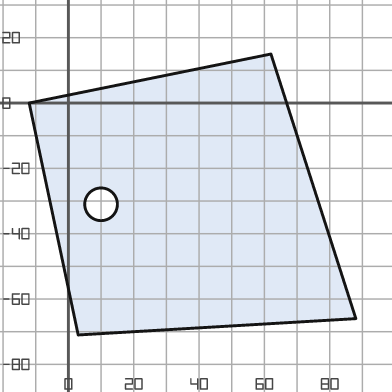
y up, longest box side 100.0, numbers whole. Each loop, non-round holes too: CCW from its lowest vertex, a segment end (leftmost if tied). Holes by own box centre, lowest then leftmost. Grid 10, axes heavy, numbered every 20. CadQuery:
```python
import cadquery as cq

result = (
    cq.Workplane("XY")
    .moveTo(3.0, -71.0)
    .lineTo(88.0, -66.0)
    .lineTo(62.0, 15.0)
    .lineTo(-12.0, 0.0)
    .close()
    .moveTo(10.0, -31.0)
    .circle(5.0)
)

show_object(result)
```